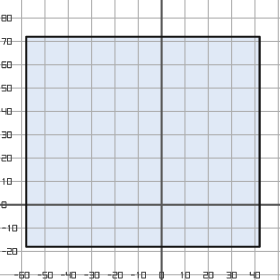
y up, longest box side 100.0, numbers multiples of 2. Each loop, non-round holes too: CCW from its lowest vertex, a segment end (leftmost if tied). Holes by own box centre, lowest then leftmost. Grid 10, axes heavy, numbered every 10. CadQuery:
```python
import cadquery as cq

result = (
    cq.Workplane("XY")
    .moveTo(-58.0, -18.0)
    .lineTo(42.0, -18.0)
    .lineTo(42.0, 72.0)
    .lineTo(-58.0, 72.0)
    .close()
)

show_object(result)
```